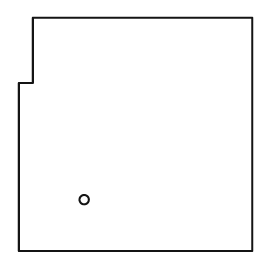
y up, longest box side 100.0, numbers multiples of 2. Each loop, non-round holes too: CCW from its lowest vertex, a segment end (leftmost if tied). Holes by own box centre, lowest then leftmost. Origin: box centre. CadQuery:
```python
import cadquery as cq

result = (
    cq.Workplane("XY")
    .moveTo(-50.0, -50.0)
    .lineTo(50.0, -50.0)
    .lineTo(50.0, 50.0)
    .lineTo(-44.0, 50.0)
    .lineTo(-44.0, 22.0)
    .lineTo(-50.0, 22.0)
    .close()
    .moveTo(-22.0, -28.0)
    .circle(2.0)
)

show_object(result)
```